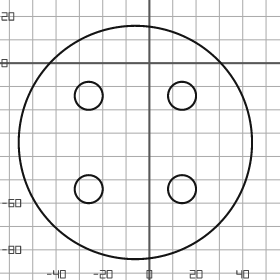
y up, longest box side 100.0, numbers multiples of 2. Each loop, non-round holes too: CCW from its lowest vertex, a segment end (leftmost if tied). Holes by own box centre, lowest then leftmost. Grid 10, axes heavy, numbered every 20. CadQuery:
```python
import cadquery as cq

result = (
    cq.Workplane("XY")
    .moveTo(-6.0, -34.0)
    .circle(50.0)
    .moveTo(-26.0, -54.0)
    .circle(6.0)
    .moveTo(14.0, -54.0)
    .circle(6.0)
    .moveTo(-26.0, -14.0)
    .circle(6.0)
    .moveTo(14.0, -14.0)
    .circle(6.0)
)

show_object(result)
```